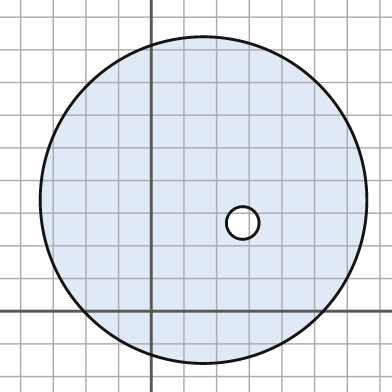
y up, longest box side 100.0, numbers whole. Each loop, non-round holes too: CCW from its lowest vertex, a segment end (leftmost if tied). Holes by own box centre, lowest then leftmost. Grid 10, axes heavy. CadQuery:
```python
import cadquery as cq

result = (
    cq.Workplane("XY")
    .moveTo(16.0, 34.0)
    .circle(50.0)
    .moveTo(28.0, 27.0)
    .circle(5.0)
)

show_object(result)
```